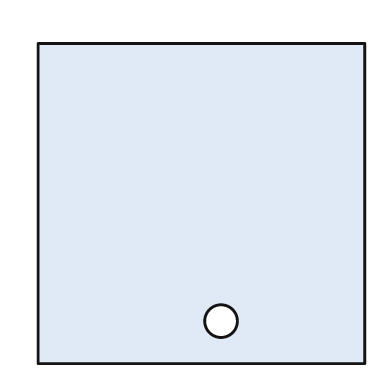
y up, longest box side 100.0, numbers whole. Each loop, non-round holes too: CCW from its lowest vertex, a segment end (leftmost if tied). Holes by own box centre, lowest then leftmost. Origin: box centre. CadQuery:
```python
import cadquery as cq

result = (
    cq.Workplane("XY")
    .moveTo(-50.0, -49.0)
    .lineTo(50.0, -49.0)
    .lineTo(50.0, 49.0)
    .lineTo(-50.0, 49.0)
    .close()
    .moveTo(6.0, -36.0)
    .circle(5.0)
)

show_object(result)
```